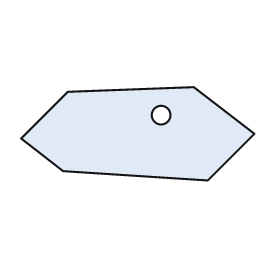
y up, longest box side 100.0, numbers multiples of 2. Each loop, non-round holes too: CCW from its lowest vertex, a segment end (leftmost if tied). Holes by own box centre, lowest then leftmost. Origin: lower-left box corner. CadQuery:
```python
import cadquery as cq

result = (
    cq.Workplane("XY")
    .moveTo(80.0, 0.0)
    .lineTo(100.0, 20.0)
    .lineTo(74.0, 40.0)
    .lineTo(20.0, 38.0)
    .lineTo(0.0, 18.0)
    .lineTo(18.0, 4.0)
    .close()
    .moveTo(60.0, 28.0)
    .circle(4.0)
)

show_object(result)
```